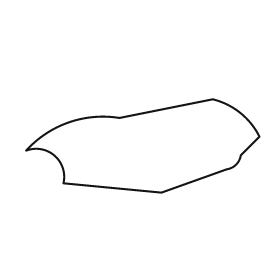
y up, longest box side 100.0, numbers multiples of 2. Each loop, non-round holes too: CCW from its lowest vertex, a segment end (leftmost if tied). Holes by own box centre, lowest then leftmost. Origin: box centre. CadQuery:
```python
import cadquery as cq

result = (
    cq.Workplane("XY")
    .moveTo(8.0, -20.0)
    .lineTo(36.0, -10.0)
    .threePointArc((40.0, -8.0), (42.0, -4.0))
    .lineTo(50.0, 4.0)
    .threePointArc((42.0, 14.0), (30.0, 20.0))
    .lineTo(-10.0, 12.0)
    .threePointArc((-32.0, 10.0), (-50.0, -2.0))
    .threePointArc((-38.0, -4.0), (-34.0, -16.0))
    .close()
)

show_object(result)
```